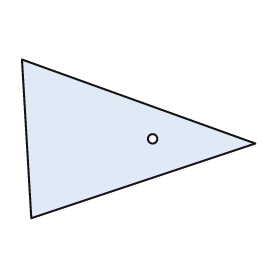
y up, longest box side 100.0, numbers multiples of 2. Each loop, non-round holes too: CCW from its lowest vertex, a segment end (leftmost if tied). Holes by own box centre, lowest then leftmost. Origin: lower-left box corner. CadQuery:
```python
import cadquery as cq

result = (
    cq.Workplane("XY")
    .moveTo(4.0, 0.0)
    .lineTo(100.0, 32.0)
    .lineTo(0.0, 68.0)
    .close()
    .moveTo(56.0, 34.0)
    .circle(2.0)
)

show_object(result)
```